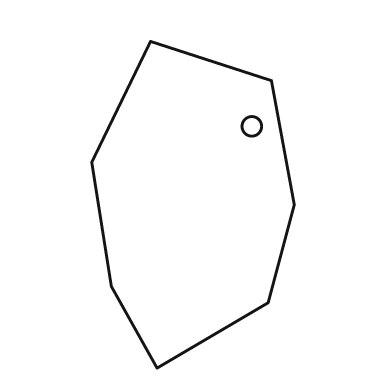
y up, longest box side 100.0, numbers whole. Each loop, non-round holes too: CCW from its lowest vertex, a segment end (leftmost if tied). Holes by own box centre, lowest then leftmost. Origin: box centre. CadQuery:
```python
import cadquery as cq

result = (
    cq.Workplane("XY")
    .moveTo(-11.0, -50.0)
    .lineTo(23.0, -30.0)
    .lineTo(31.0, 0.0)
    .lineTo(24.0, 38.0)
    .lineTo(-13.0, 50.0)
    .lineTo(-31.0, 13.0)
    .lineTo(-25.0, -25.0)
    .close()
    .moveTo(18.0, 24.0)
    .circle(3.0)
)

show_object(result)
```